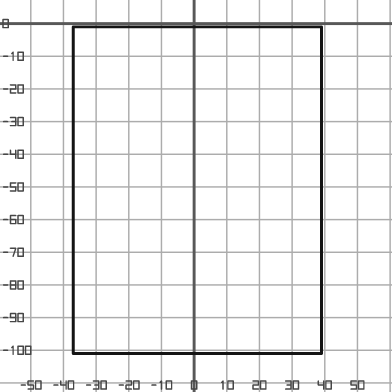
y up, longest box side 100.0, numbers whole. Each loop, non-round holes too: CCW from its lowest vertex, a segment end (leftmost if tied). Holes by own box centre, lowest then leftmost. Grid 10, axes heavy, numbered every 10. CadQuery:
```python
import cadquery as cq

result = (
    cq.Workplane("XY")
    .moveTo(-37.0, -101.0)
    .lineTo(39.0, -101.0)
    .lineTo(39.0, -1.0)
    .lineTo(-37.0, -1.0)
    .close()
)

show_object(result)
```